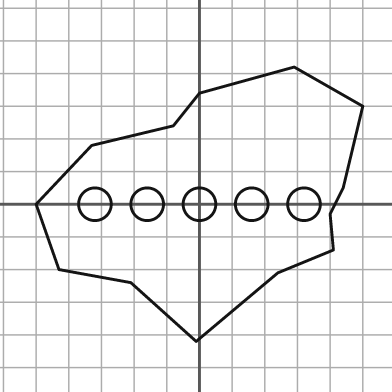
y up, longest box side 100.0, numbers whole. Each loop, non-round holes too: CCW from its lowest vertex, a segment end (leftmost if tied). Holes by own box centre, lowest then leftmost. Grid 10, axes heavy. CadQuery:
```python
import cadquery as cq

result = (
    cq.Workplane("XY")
    .moveTo(-1.0, -42.0)
    .lineTo(24.0, -21.0)
    .lineTo(41.0, -14.0)
    .lineTo(40.0, -3.0)
    .lineTo(44.0, 5.0)
    .lineTo(50.0, 30.0)
    .lineTo(29.0, 42.0)
    .lineTo(0.0, 34.0)
    .lineTo(-8.0, 24.0)
    .lineTo(-33.0, 18.0)
    .lineTo(-50.0, 0.0)
    .lineTo(-43.0, -20.0)
    .lineTo(-21.0, -24.0)
    .close()
    .moveTo(-32.0, 0.0)
    .circle(5.0)
    .moveTo(-16.0, 0.0)
    .circle(5.0)
    .moveTo(0.0, 0.0)
    .circle(5.0)
    .moveTo(16.0, 0.0)
    .circle(5.0)
    .moveTo(32.0, 0.0)
    .circle(5.0)
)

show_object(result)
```